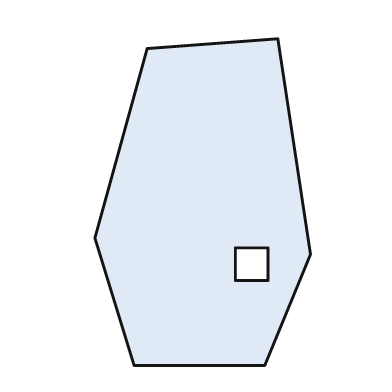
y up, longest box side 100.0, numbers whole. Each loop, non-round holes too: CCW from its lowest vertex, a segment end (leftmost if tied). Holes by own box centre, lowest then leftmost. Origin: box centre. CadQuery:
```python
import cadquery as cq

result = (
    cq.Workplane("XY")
    .moveTo(-21.0, -50.0)
    .lineTo(19.0, -50.0)
    .lineTo(33.0, -16.0)
    .lineTo(23.0, 50.0)
    .lineTo(-17.0, 47.0)
    .lineTo(-33.0, -11.0)
    .close()
    .moveTo(10.0, -24.0)
    .lineTo(20.0, -24.0)
    .lineTo(20.0, -14.0)
    .lineTo(10.0, -14.0)
    .close()
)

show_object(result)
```